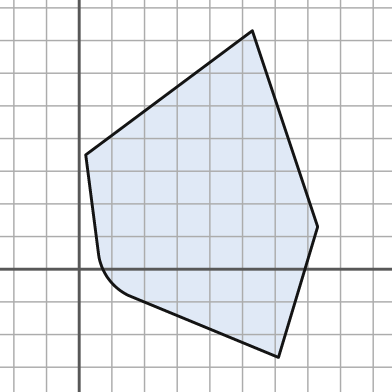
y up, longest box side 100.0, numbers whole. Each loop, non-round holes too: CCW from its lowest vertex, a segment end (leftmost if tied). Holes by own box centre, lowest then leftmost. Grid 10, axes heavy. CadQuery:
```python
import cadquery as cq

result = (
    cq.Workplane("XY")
    .moveTo(61.0, -27.0)
    .lineTo(73.0, 13.0)
    .lineTo(53.0, 73.0)
    .lineTo(2.0, 35.0)
    .lineTo(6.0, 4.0)
    .threePointArc((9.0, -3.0), (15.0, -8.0))
    .close()
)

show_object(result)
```